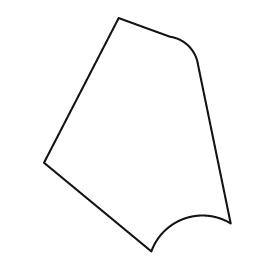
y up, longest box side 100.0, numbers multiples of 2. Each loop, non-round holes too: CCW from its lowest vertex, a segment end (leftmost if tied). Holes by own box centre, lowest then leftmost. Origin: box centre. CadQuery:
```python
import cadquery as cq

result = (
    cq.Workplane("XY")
    .moveTo(6.0, -50.0)
    .threePointArc((20.0, -36.0), (40.0, -38.0))
    .lineTo(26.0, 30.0)
    .threePointArc((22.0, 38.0), (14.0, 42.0))
    .lineTo(-8.0, 50.0)
    .lineTo(-40.0, -12.0)
    .close()
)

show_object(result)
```